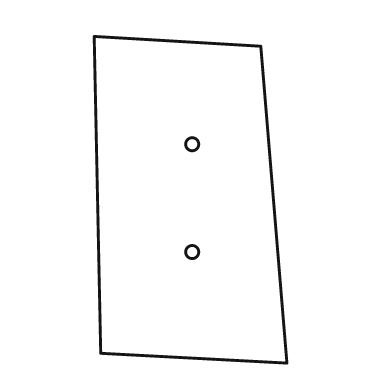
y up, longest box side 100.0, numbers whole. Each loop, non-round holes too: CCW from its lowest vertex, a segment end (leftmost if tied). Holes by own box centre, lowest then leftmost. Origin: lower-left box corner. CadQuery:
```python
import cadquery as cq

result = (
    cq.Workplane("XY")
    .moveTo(59.0, 0.0)
    .lineTo(51.0, 97.0)
    .lineTo(0.0, 100.0)
    .lineTo(2.0, 3.0)
    .close()
    .moveTo(30.0, 34.0)
    .circle(2.0)
    .moveTo(30.0, 67.0)
    .circle(2.0)
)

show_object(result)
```